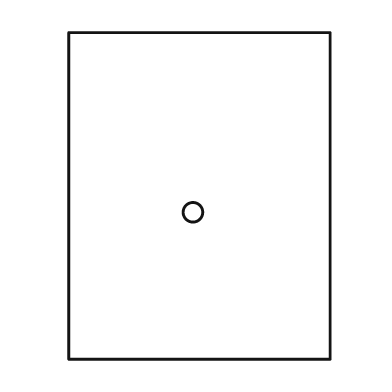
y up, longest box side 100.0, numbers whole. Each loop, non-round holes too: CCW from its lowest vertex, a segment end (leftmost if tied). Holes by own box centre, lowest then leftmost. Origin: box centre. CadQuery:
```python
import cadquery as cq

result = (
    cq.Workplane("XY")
    .moveTo(-40.0, -50.0)
    .lineTo(40.0, -50.0)
    .lineTo(40.0, 50.0)
    .lineTo(-40.0, 50.0)
    .close()
    .moveTo(-2.0, -5.0)
    .circle(3.0)
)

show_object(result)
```